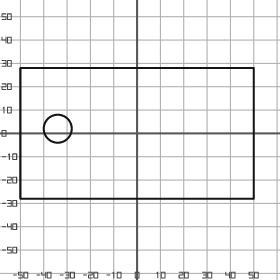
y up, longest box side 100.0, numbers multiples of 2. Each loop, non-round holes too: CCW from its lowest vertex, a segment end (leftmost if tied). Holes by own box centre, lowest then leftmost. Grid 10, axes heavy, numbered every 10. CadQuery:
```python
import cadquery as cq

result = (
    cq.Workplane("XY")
    .moveTo(-50.0, -28.0)
    .lineTo(50.0, -28.0)
    .lineTo(50.0, 28.0)
    .lineTo(-50.0, 28.0)
    .close()
    .moveTo(-34.0, 2.0)
    .circle(6.0)
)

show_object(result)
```